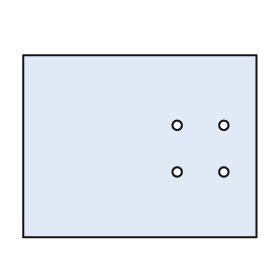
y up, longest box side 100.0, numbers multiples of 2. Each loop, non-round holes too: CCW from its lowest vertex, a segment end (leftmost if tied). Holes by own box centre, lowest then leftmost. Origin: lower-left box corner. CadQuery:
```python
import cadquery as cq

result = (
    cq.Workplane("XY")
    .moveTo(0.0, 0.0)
    .lineTo(100.0, 0.0)
    .lineTo(100.0, 78.0)
    .lineTo(0.0, 78.0)
    .close()
    .moveTo(66.0, 28.0)
    .circle(2.0)
    .moveTo(86.0, 28.0)
    .circle(2.0)
    .moveTo(66.0, 48.0)
    .circle(2.0)
    .moveTo(86.0, 48.0)
    .circle(2.0)
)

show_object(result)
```